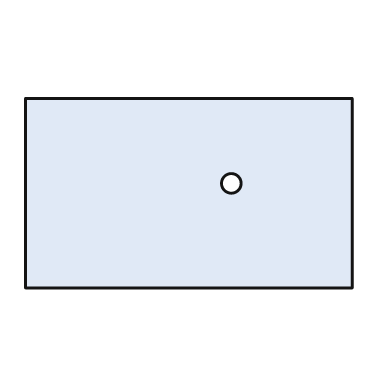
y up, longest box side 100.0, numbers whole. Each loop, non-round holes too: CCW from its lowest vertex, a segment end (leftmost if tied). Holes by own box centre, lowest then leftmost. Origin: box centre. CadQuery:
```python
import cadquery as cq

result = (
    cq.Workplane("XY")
    .moveTo(-50.0, -29.0)
    .lineTo(50.0, -29.0)
    .lineTo(50.0, 29.0)
    .lineTo(-50.0, 29.0)
    .close()
    .moveTo(13.0, 3.0)
    .circle(3.0)
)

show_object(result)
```